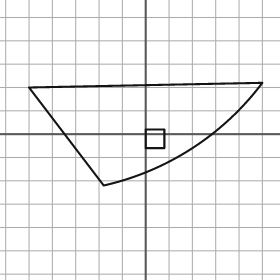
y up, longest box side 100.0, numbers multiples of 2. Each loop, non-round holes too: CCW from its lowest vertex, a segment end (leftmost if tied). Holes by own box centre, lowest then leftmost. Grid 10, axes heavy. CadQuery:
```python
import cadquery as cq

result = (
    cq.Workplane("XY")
    .moveTo(-18.0, -22.0)
    .threePointArc((20.0, -6.0), (50.0, 22.0))
    .lineTo(-50.0, 20.0)
    .close()
    .moveTo(0.0, -6.0)
    .lineTo(8.0, -6.0)
    .lineTo(8.0, 2.0)
    .lineTo(0.0, 2.0)
    .close()
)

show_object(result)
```